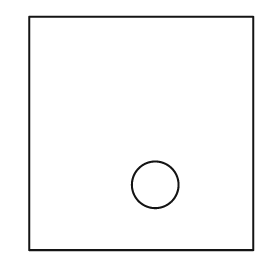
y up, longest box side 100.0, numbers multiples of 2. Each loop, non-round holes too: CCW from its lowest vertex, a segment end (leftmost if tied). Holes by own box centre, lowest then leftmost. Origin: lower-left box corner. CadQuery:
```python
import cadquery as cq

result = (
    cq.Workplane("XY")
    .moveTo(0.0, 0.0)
    .lineTo(96.0, 0.0)
    .lineTo(96.0, 100.0)
    .lineTo(0.0, 100.0)
    .close()
    .moveTo(54.0, 28.0)
    .circle(10.0)
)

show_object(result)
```